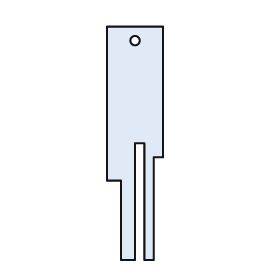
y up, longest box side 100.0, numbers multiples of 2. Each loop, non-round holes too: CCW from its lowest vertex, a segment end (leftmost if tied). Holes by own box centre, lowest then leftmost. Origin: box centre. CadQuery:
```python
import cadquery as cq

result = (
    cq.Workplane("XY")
    .moveTo(-6.0, -50.0)
    .lineTo(0.0, -50.0)
    .lineTo(0.0, 0.0)
    .lineTo(4.0, 0.0)
    .lineTo(4.0, -50.0)
    .lineTo(8.0, -50.0)
    .lineTo(8.0, -6.0)
    .lineTo(12.0, -6.0)
    .lineTo(12.0, 50.0)
    .lineTo(-12.0, 50.0)
    .lineTo(-12.0, -16.0)
    .lineTo(-6.0, -16.0)
    .close()
    .moveTo(0.0, 44.0)
    .circle(2.0)
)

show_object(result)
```